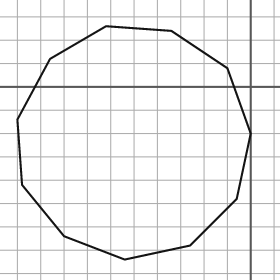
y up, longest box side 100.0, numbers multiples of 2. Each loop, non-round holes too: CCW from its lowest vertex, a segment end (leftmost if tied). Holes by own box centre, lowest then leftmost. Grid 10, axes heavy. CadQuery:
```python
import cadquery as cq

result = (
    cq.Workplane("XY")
    .moveTo(-54.0, -74.0)
    .lineTo(-26.0, -68.0)
    .lineTo(-6.0, -48.0)
    .lineTo(0.0, -20.0)
    .lineTo(-10.0, 8.0)
    .lineTo(-34.0, 24.0)
    .lineTo(-62.0, 26.0)
    .lineTo(-86.0, 12.0)
    .lineTo(-100.0, -14.0)
    .lineTo(-98.0, -42.0)
    .lineTo(-80.0, -64.0)
    .close()
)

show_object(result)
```